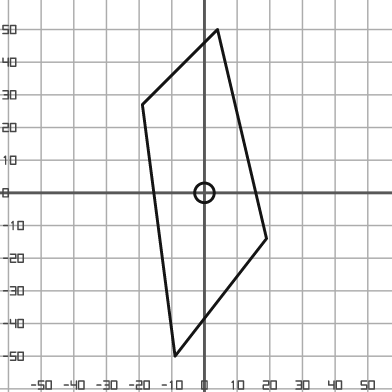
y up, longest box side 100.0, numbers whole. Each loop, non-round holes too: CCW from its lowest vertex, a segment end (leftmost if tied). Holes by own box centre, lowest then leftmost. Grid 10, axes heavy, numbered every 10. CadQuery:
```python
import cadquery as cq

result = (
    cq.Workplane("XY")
    .moveTo(-9.0, -50.0)
    .lineTo(19.0, -14.0)
    .lineTo(4.0, 50.0)
    .lineTo(-19.0, 27.0)
    .close()
    .moveTo(0.0, 0.0)
    .circle(3.0)
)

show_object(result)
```